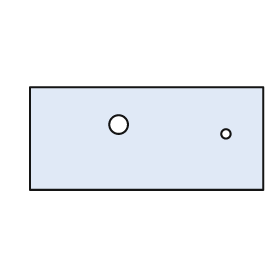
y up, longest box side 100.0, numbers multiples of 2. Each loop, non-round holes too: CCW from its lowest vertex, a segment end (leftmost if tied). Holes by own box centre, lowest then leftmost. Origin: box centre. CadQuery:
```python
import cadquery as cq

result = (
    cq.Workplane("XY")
    .moveTo(-50.0, -22.0)
    .lineTo(50.0, -22.0)
    .lineTo(50.0, 22.0)
    .lineTo(-50.0, 22.0)
    .close()
    .moveTo(34.0, 2.0)
    .circle(2.0)
    .moveTo(-12.0, 6.0)
    .circle(4.0)
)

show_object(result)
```